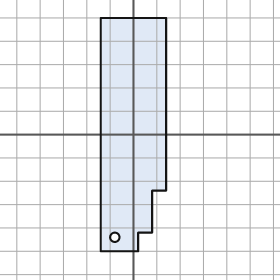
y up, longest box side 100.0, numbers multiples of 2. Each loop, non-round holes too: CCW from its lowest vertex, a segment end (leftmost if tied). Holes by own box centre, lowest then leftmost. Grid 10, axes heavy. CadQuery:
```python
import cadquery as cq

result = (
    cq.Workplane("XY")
    .moveTo(-14.0, -50.0)
    .lineTo(2.0, -50.0)
    .lineTo(2.0, -42.0)
    .lineTo(8.0, -42.0)
    .lineTo(8.0, -24.0)
    .lineTo(14.0, -24.0)
    .lineTo(14.0, 50.0)
    .lineTo(-14.0, 50.0)
    .close()
    .moveTo(-8.0, -44.0)
    .circle(2.0)
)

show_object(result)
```